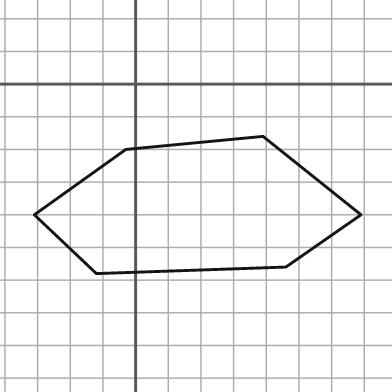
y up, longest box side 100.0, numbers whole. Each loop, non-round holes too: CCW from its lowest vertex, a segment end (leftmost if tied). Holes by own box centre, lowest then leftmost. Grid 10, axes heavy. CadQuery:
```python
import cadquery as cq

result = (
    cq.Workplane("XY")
    .moveTo(-12.0, -58.0)
    .lineTo(46.0, -56.0)
    .lineTo(69.0, -40.0)
    .lineTo(39.0, -16.0)
    .lineTo(-3.0, -20.0)
    .lineTo(-31.0, -40.0)
    .close()
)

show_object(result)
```